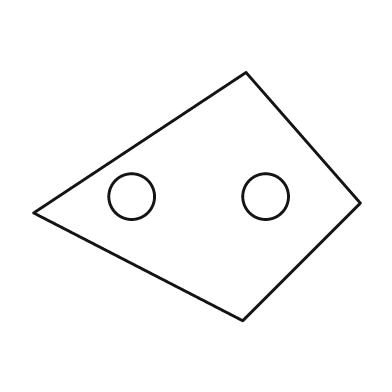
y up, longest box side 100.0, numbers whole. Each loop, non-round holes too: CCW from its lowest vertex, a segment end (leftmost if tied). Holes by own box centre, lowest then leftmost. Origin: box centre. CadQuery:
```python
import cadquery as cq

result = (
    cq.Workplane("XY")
    .moveTo(14.0, -38.0)
    .lineTo(50.0, -2.0)
    .lineTo(15.0, 38.0)
    .lineTo(-50.0, -5.0)
    .close()
    .moveTo(-20.0, 0.0)
    .circle(7.0)
    .moveTo(21.0, 0.0)
    .circle(7.0)
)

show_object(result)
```